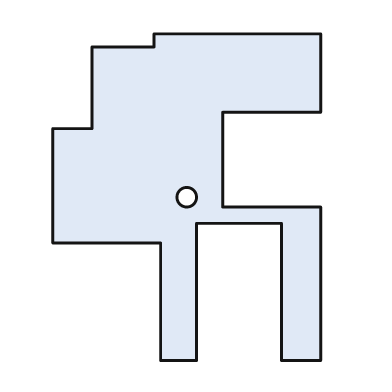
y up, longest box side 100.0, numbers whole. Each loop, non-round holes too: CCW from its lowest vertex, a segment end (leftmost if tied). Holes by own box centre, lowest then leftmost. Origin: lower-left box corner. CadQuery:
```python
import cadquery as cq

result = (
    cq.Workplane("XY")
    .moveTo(33.0, 0.0)
    .lineTo(44.0, 0.0)
    .lineTo(44.0, 42.0)
    .lineTo(70.0, 42.0)
    .lineTo(70.0, 0.0)
    .lineTo(82.0, 0.0)
    .lineTo(82.0, 47.0)
    .lineTo(52.0, 47.0)
    .lineTo(52.0, 76.0)
    .lineTo(82.0, 76.0)
    .lineTo(82.0, 100.0)
    .lineTo(31.0, 100.0)
    .lineTo(31.0, 96.0)
    .lineTo(12.0, 96.0)
    .lineTo(12.0, 71.0)
    .lineTo(0.0, 71.0)
    .lineTo(0.0, 36.0)
    .lineTo(33.0, 36.0)
    .close()
    .moveTo(41.0, 50.0)
    .circle(3.0)
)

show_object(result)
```